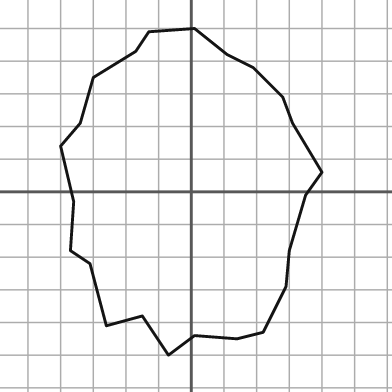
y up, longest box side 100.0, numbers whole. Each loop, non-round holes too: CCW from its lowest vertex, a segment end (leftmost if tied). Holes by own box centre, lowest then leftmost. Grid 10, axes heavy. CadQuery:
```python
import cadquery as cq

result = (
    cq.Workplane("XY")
    .moveTo(-7.0, -50.0)
    .lineTo(1.0, -44.0)
    .lineTo(14.0, -45.0)
    .lineTo(22.0, -43.0)
    .lineTo(29.0, -29.0)
    .lineTo(30.0, -18.0)
    .lineTo(35.0, -1.0)
    .lineTo(40.0, 6.0)
    .lineTo(31.0, 21.0)
    .lineTo(28.0, 29.0)
    .lineTo(19.0, 38.0)
    .lineTo(11.0, 42.0)
    .lineTo(1.0, 50.0)
    .lineTo(-13.0, 49.0)
    .lineTo(-17.0, 43.0)
    .lineTo(-30.0, 35.0)
    .lineTo(-34.0, 21.0)
    .lineTo(-40.0, 14.0)
    .lineTo(-36.0, -3.0)
    .lineTo(-37.0, -18.0)
    .lineTo(-31.0, -22.0)
    .lineTo(-26.0, -41.0)
    .lineTo(-15.0, -38.0)
    .close()
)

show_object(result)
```